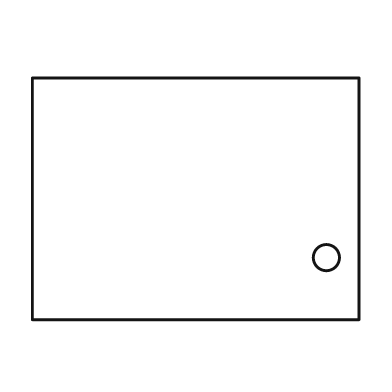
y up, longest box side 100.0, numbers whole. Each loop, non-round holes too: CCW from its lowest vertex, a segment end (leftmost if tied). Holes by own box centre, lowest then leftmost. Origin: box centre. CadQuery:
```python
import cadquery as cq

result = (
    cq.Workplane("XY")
    .moveTo(-50.0, -37.0)
    .lineTo(50.0, -37.0)
    .lineTo(50.0, 37.0)
    .lineTo(-50.0, 37.0)
    .close()
    .moveTo(40.0, -18.0)
    .circle(4.0)
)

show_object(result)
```